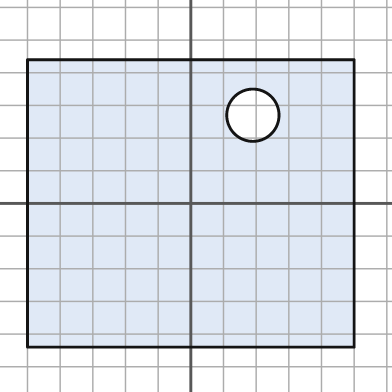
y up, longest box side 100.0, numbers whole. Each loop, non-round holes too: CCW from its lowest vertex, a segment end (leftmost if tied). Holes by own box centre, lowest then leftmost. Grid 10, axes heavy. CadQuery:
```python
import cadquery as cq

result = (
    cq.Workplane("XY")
    .moveTo(-50.0, -44.0)
    .lineTo(50.0, -44.0)
    .lineTo(50.0, 44.0)
    .lineTo(-50.0, 44.0)
    .close()
    .moveTo(19.0, 27.0)
    .circle(8.0)
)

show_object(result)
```